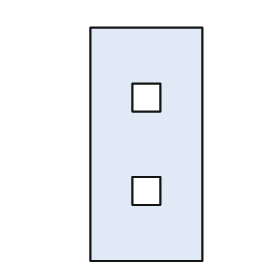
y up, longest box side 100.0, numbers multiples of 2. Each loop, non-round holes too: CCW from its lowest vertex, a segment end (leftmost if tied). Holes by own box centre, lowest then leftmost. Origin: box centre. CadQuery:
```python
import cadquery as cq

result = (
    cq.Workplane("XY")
    .moveTo(-24.0, -50.0)
    .lineTo(24.0, -50.0)
    .lineTo(24.0, 50.0)
    .lineTo(-24.0, 50.0)
    .close()
    .moveTo(-6.0, -26.0)
    .lineTo(6.0, -26.0)
    .lineTo(6.0, -14.0)
    .lineTo(-6.0, -14.0)
    .close()
    .moveTo(-6.0, 14.0)
    .lineTo(6.0, 14.0)
    .lineTo(6.0, 26.0)
    .lineTo(-6.0, 26.0)
    .close()
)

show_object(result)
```